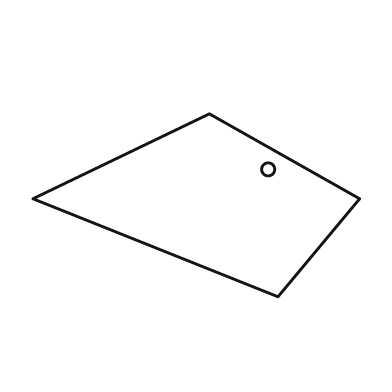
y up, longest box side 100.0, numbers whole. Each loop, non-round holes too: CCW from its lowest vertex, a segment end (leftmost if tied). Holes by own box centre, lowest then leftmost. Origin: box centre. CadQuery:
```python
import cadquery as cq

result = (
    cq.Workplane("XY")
    .moveTo(25.0, -28.0)
    .lineTo(50.0, 2.0)
    .lineTo(4.0, 28.0)
    .lineTo(-50.0, 2.0)
    .close()
    .moveTo(22.0, 11.0)
    .circle(2.0)
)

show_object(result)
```